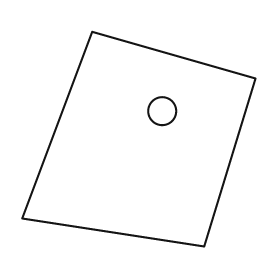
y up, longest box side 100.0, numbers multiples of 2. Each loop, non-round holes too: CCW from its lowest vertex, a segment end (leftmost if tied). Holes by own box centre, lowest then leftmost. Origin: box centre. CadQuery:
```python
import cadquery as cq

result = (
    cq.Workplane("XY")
    .moveTo(28.0, -46.0)
    .lineTo(50.0, 26.0)
    .lineTo(-20.0, 46.0)
    .lineTo(-50.0, -34.0)
    .close()
    .moveTo(10.0, 12.0)
    .circle(6.0)
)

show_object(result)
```